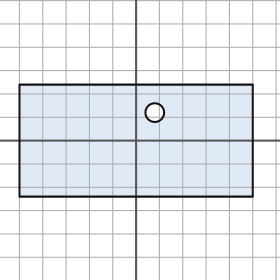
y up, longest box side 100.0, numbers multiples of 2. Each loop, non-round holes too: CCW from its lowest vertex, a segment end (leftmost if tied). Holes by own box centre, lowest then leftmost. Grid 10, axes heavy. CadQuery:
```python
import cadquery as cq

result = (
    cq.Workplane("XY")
    .moveTo(-50.0, -24.0)
    .lineTo(50.0, -24.0)
    .lineTo(50.0, 24.0)
    .lineTo(-50.0, 24.0)
    .close()
    .moveTo(8.0, 12.0)
    .circle(4.0)
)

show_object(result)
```